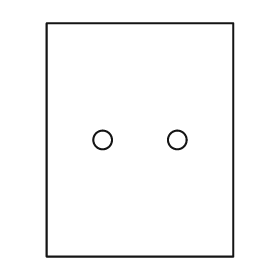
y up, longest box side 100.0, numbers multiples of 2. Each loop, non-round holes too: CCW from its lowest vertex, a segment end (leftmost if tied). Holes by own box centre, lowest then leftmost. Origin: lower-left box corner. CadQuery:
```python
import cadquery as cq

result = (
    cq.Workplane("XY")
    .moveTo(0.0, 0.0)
    .lineTo(80.0, 0.0)
    .lineTo(80.0, 100.0)
    .lineTo(0.0, 100.0)
    .close()
    .moveTo(24.0, 50.0)
    .circle(4.0)
    .moveTo(56.0, 50.0)
    .circle(4.0)
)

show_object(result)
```